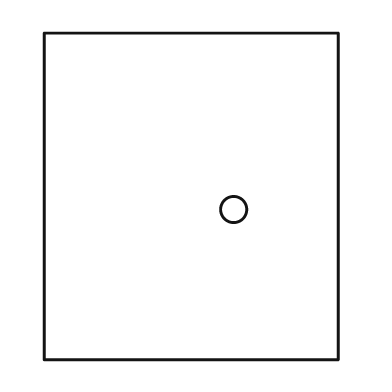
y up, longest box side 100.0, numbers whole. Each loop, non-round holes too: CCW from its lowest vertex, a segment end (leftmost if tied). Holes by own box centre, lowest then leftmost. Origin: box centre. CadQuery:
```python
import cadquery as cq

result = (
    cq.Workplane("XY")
    .moveTo(-45.0, -50.0)
    .lineTo(45.0, -50.0)
    .lineTo(45.0, 50.0)
    .lineTo(-45.0, 50.0)
    .close()
    .moveTo(13.0, -4.0)
    .circle(4.0)
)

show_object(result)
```